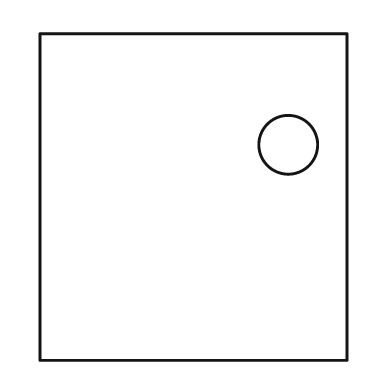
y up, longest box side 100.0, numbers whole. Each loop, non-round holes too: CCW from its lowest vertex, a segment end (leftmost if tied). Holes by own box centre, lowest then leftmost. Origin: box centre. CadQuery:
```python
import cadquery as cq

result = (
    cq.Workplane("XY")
    .moveTo(-47.0, -50.0)
    .lineTo(47.0, -50.0)
    .lineTo(47.0, 50.0)
    .lineTo(-47.0, 50.0)
    .close()
    .moveTo(29.0, 16.0)
    .circle(9.0)
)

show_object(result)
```